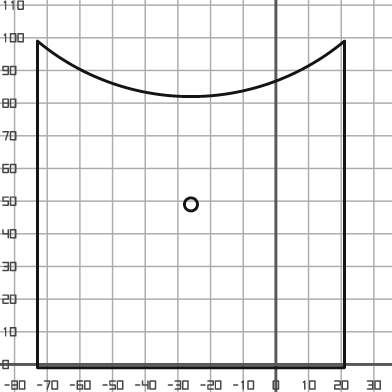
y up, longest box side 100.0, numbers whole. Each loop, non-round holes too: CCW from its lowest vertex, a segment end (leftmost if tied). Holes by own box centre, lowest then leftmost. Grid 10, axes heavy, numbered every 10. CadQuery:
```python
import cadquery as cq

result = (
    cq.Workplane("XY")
    .moveTo(-73.0, -1.0)
    .lineTo(21.0, -1.0)
    .lineTo(21.0, 99.0)
    .threePointArc((-26.0, 82.0), (-73.0, 99.0))
    .close()
    .moveTo(-26.0, 49.0)
    .circle(2.0)
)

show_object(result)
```